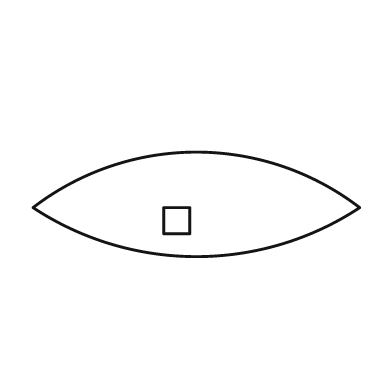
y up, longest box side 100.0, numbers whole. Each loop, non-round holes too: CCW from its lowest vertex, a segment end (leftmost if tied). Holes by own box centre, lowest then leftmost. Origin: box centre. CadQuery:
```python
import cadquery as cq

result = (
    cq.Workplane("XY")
    .moveTo(-50.0, -1.0)
    .threePointArc((0.0, -16.0), (50.0, -1.0))
    .threePointArc((0.0, 16.0), (-50.0, -1.0))
    .close()
    .moveTo(-10.0, -9.0)
    .lineTo(-2.0, -9.0)
    .lineTo(-2.0, -1.0)
    .lineTo(-10.0, -1.0)
    .close()
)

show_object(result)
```